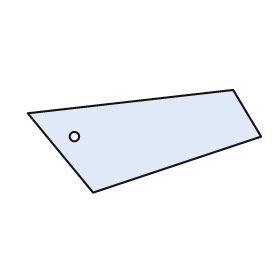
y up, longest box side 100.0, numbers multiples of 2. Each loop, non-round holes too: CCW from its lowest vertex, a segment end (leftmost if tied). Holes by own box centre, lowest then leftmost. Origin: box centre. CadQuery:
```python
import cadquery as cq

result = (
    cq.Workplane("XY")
    .moveTo(-22.0, -22.0)
    .lineTo(50.0, 2.0)
    .lineTo(38.0, 22.0)
    .lineTo(-50.0, 12.0)
    .close()
    .moveTo(-30.0, 2.0)
    .circle(2.0)
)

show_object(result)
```